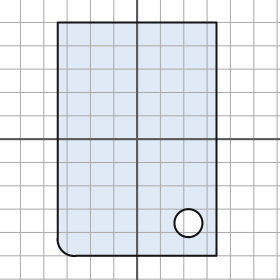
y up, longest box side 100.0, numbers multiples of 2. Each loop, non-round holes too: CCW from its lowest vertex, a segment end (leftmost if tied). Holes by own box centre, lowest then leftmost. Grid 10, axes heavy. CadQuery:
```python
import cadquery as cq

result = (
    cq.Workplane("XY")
    .moveTo(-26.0, -50.0)
    .lineTo(34.0, -50.0)
    .lineTo(34.0, 50.0)
    .lineTo(-34.0, 50.0)
    .lineTo(-34.0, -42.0)
    .threePointArc((-32.0, -48.0), (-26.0, -50.0))
    .close()
    .moveTo(22.0, -36.0)
    .circle(6.0)
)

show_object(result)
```